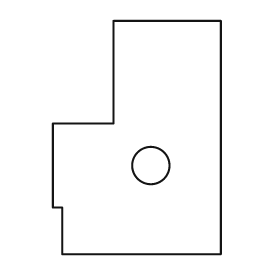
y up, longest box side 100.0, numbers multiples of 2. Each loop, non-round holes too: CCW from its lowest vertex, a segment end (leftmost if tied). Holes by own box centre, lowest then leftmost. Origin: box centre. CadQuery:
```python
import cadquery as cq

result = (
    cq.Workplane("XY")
    .moveTo(-32.0, -50.0)
    .lineTo(36.0, -50.0)
    .lineTo(36.0, 50.0)
    .lineTo(-10.0, 50.0)
    .lineTo(-10.0, 6.0)
    .lineTo(-36.0, 6.0)
    .lineTo(-36.0, -30.0)
    .lineTo(-32.0, -30.0)
    .close()
    .moveTo(6.0, -12.0)
    .circle(8.0)
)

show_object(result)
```